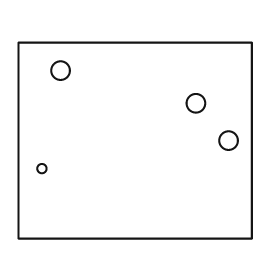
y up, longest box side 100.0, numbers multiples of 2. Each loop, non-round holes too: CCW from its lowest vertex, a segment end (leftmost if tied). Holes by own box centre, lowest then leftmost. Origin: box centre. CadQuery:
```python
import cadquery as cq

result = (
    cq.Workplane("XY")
    .moveTo(-50.0, -42.0)
    .lineTo(50.0, -42.0)
    .lineTo(50.0, 42.0)
    .lineTo(-50.0, 42.0)
    .close()
    .moveTo(-40.0, -12.0)
    .circle(2.0)
    .moveTo(40.0, 0.0)
    .circle(4.0)
    .moveTo(26.0, 16.0)
    .circle(4.0)
    .moveTo(-32.0, 30.0)
    .circle(4.0)
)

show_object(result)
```